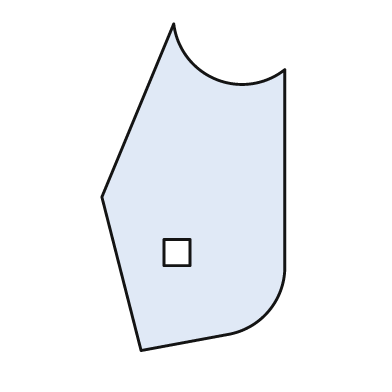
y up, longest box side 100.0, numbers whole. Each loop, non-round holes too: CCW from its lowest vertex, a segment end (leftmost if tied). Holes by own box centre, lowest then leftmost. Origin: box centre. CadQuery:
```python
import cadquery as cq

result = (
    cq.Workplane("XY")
    .moveTo(-16.0, -50.0)
    .lineTo(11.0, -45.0)
    .threePointArc((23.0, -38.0), (28.0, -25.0))
    .lineTo(28.0, 36.0)
    .threePointArc((7.0, 33.0), (-6.0, 50.0))
    .lineTo(-28.0, -3.0)
    .close()
    .moveTo(-9.0, -24.0)
    .lineTo(-1.0, -24.0)
    .lineTo(-1.0, -16.0)
    .lineTo(-9.0, -16.0)
    .close()
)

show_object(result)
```